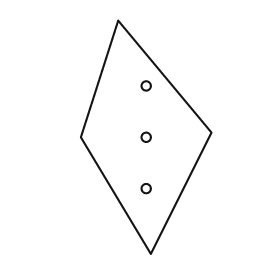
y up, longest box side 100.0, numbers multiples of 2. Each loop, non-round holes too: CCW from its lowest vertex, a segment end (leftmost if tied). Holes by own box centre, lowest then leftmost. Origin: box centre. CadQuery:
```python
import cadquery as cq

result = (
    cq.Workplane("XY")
    .moveTo(2.0, -50.0)
    .lineTo(28.0, 2.0)
    .lineTo(-12.0, 50.0)
    .lineTo(-28.0, 0.0)
    .close()
    .moveTo(0.0, -22.0)
    .circle(2.0)
    .moveTo(0.0, 0.0)
    .circle(2.0)
    .moveTo(0.0, 22.0)
    .circle(2.0)
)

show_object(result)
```